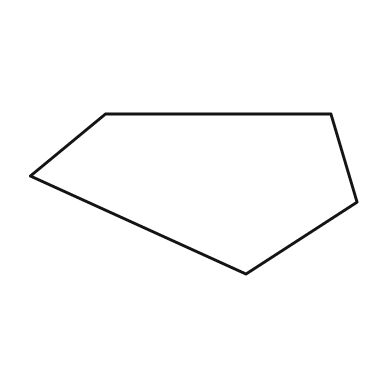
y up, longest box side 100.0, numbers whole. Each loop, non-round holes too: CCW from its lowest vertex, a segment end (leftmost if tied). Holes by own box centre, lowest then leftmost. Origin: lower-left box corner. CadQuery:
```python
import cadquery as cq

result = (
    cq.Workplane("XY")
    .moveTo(66.0, 0.0)
    .lineTo(100.0, 22.0)
    .lineTo(92.0, 49.0)
    .lineTo(23.0, 49.0)
    .lineTo(0.0, 30.0)
    .close()
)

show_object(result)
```